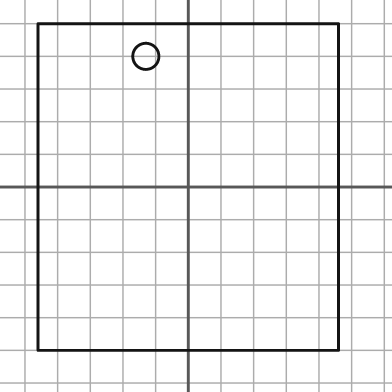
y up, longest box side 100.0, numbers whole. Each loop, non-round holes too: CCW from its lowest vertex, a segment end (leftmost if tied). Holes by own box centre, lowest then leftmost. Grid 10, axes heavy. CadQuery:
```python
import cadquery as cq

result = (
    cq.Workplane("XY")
    .moveTo(-46.0, -50.0)
    .lineTo(46.0, -50.0)
    .lineTo(46.0, 50.0)
    .lineTo(-46.0, 50.0)
    .close()
    .moveTo(-13.0, 40.0)
    .circle(4.0)
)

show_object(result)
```